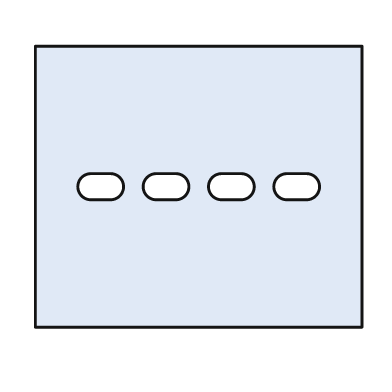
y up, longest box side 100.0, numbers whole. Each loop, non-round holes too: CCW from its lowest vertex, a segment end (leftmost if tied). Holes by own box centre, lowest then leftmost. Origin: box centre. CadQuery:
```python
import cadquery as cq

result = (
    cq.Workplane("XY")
    .moveTo(-50.0, -43.0)
    .lineTo(50.0, -43.0)
    .lineTo(50.0, 43.0)
    .lineTo(-50.0, 43.0)
    .close()
    .moveTo(-33.0, -4.0)
    .lineTo(-27.0, -4.0)
    .threePointArc((-23.0, 0.0), (-27.0, 4.0))
    .lineTo(-33.0, 4.0)
    .threePointArc((-37.0, 0.0), (-33.0, -4.0))
    .close()
    .moveTo(-13.0, -4.0)
    .lineTo(-7.0, -4.0)
    .threePointArc((-3.0, 0.0), (-7.0, 4.0))
    .lineTo(-13.0, 4.0)
    .threePointArc((-17.0, 0.0), (-13.0, -4.0))
    .close()
    .moveTo(7.0, -4.0)
    .lineTo(13.0, -4.0)
    .threePointArc((17.0, 0.0), (13.0, 4.0))
    .lineTo(7.0, 4.0)
    .threePointArc((3.0, 0.0), (7.0, -4.0))
    .close()
    .moveTo(27.0, -4.0)
    .lineTo(33.0, -4.0)
    .threePointArc((37.0, 0.0), (33.0, 4.0))
    .lineTo(27.0, 4.0)
    .threePointArc((23.0, 0.0), (27.0, -4.0))
    .close()
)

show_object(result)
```